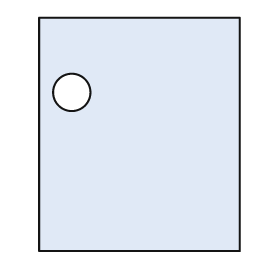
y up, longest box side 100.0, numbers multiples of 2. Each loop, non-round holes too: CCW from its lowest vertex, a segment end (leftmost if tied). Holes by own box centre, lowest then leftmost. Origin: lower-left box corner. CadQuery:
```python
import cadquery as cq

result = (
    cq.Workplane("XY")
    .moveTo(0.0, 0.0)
    .lineTo(86.0, 0.0)
    .lineTo(86.0, 100.0)
    .lineTo(0.0, 100.0)
    .close()
    .moveTo(14.0, 68.0)
    .circle(8.0)
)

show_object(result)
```